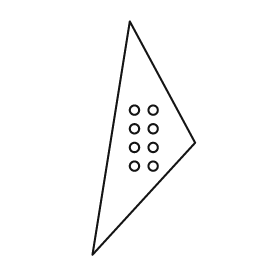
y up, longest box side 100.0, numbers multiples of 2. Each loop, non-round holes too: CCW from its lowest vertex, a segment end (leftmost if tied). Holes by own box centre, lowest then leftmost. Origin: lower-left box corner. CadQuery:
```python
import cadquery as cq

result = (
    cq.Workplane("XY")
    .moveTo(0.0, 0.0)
    .lineTo(44.0, 48.0)
    .lineTo(16.0, 100.0)
    .close()
    .moveTo(18.0, 38.0)
    .circle(2.0)
    .moveTo(26.0, 38.0)
    .circle(2.0)
    .moveTo(18.0, 46.0)
    .circle(2.0)
    .moveTo(26.0, 46.0)
    .circle(2.0)
    .moveTo(18.0, 54.0)
    .circle(2.0)
    .moveTo(26.0, 54.0)
    .circle(2.0)
    .moveTo(18.0, 62.0)
    .circle(2.0)
    .moveTo(26.0, 62.0)
    .circle(2.0)
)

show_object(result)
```